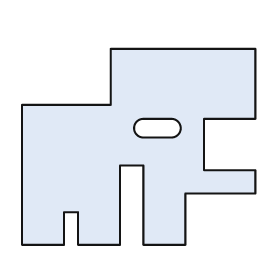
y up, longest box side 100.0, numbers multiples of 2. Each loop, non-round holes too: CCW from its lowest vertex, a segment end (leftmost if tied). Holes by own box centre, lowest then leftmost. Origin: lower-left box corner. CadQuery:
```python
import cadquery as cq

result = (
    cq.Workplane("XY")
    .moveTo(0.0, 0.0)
    .lineTo(18.0, 0.0)
    .lineTo(18.0, 14.0)
    .lineTo(24.0, 14.0)
    .lineTo(24.0, 0.0)
    .lineTo(42.0, 0.0)
    .lineTo(42.0, 34.0)
    .lineTo(52.0, 34.0)
    .lineTo(52.0, 0.0)
    .lineTo(70.0, 0.0)
    .lineTo(70.0, 22.0)
    .lineTo(100.0, 22.0)
    .lineTo(100.0, 32.0)
    .lineTo(78.0, 32.0)
    .lineTo(78.0, 54.0)
    .lineTo(100.0, 54.0)
    .lineTo(100.0, 84.0)
    .lineTo(38.0, 84.0)
    .lineTo(38.0, 60.0)
    .lineTo(0.0, 60.0)
    .close()
    .moveTo(52.0, 46.0)
    .lineTo(64.0, 46.0)
    .threePointArc((68.0, 50.0), (64.0, 54.0))
    .lineTo(52.0, 54.0)
    .threePointArc((48.0, 50.0), (52.0, 46.0))
    .close()
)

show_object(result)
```